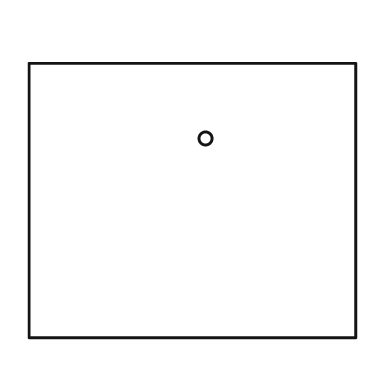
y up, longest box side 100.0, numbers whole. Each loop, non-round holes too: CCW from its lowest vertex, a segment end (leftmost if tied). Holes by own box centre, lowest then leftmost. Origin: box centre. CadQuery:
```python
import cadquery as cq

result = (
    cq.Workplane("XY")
    .moveTo(-50.0, -42.0)
    .lineTo(50.0, -42.0)
    .lineTo(50.0, 42.0)
    .lineTo(-50.0, 42.0)
    .close()
    .moveTo(4.0, 19.0)
    .circle(2.0)
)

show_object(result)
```